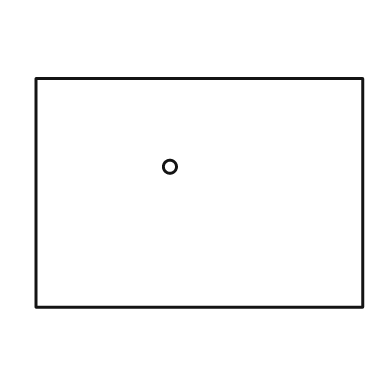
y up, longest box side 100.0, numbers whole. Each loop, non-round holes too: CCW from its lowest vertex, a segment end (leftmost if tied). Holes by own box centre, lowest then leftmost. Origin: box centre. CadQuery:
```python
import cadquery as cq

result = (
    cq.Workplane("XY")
    .moveTo(-50.0, -35.0)
    .lineTo(50.0, -35.0)
    .lineTo(50.0, 35.0)
    .lineTo(-50.0, 35.0)
    .close()
    .moveTo(-9.0, 8.0)
    .circle(2.0)
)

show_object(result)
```